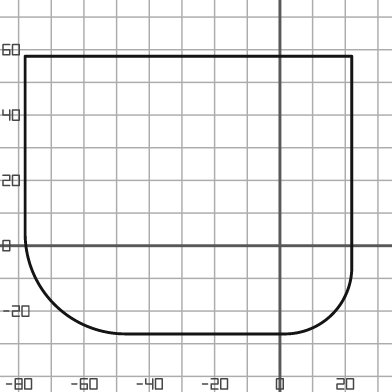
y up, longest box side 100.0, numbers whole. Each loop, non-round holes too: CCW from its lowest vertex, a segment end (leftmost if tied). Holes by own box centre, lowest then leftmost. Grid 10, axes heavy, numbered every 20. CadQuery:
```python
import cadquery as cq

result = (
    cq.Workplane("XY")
    .moveTo(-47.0, -27.0)
    .lineTo(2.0, -27.0)
    .threePointArc((16.0, -21.0), (22.0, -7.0))
    .lineTo(22.0, 58.0)
    .lineTo(-78.0, 58.0)
    .lineTo(-78.0, 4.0)
    .threePointArc((-69.0, -18.0), (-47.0, -27.0))
    .close()
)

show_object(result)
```